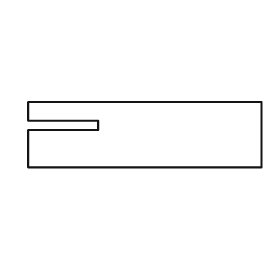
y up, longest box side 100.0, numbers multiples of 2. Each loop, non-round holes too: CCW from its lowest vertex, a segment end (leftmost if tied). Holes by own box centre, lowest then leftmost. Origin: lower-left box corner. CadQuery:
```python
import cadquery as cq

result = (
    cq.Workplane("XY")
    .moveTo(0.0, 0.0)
    .lineTo(100.0, 0.0)
    .lineTo(100.0, 28.0)
    .lineTo(0.0, 28.0)
    .lineTo(0.0, 20.0)
    .lineTo(30.0, 20.0)
    .lineTo(30.0, 16.0)
    .lineTo(0.0, 16.0)
    .close()
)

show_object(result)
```